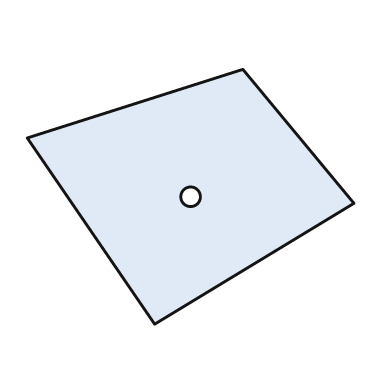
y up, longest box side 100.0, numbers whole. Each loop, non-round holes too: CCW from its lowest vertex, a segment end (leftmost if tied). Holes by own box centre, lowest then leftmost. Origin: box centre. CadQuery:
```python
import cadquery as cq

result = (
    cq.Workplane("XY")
    .moveTo(-11.0, -39.0)
    .lineTo(50.0, -2.0)
    .lineTo(16.0, 39.0)
    .lineTo(-50.0, 18.0)
    .close()
    .moveTo(0.0, 0.0)
    .circle(3.0)
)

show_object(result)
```